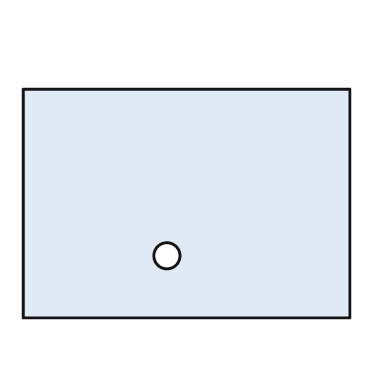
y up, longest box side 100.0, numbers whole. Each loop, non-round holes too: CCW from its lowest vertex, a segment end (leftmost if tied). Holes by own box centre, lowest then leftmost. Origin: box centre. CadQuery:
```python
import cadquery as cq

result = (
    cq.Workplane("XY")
    .moveTo(-50.0, -35.0)
    .lineTo(50.0, -35.0)
    .lineTo(50.0, 35.0)
    .lineTo(-50.0, 35.0)
    .close()
    .moveTo(-6.0, -16.0)
    .circle(4.0)
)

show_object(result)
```